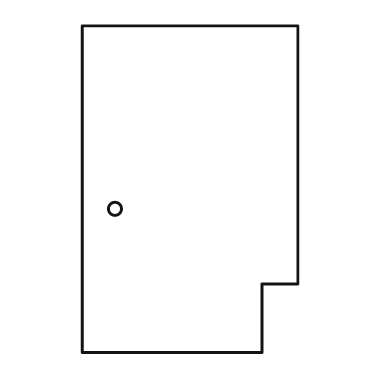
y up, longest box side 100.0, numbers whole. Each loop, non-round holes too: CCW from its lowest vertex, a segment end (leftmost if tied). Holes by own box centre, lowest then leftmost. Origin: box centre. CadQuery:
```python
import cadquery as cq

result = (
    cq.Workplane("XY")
    .moveTo(-33.0, -50.0)
    .lineTo(22.0, -50.0)
    .lineTo(22.0, -29.0)
    .lineTo(33.0, -29.0)
    .lineTo(33.0, 50.0)
    .lineTo(-33.0, 50.0)
    .close()
    .moveTo(-23.0, -6.0)
    .circle(2.0)
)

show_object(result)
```